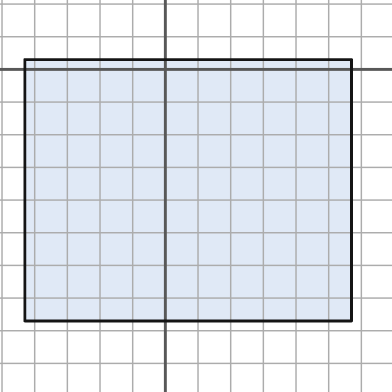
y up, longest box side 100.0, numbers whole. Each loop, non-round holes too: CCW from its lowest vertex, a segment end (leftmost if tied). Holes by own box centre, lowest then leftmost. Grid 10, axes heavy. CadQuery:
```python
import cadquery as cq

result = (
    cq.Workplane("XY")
    .moveTo(-43.0, -77.0)
    .lineTo(57.0, -77.0)
    .lineTo(57.0, 3.0)
    .lineTo(-43.0, 3.0)
    .close()
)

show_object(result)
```